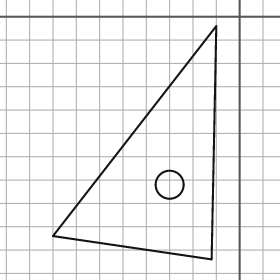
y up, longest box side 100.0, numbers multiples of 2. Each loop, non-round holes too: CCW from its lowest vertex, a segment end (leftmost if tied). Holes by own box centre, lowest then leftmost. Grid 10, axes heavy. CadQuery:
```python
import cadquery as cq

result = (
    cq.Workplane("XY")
    .moveTo(-12.0, -104.0)
    .lineTo(-10.0, -4.0)
    .lineTo(-80.0, -94.0)
    .close()
    .moveTo(-30.0, -72.0)
    .circle(6.0)
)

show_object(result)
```